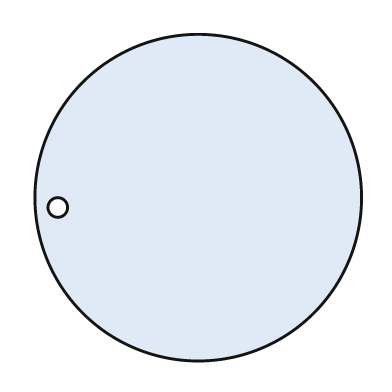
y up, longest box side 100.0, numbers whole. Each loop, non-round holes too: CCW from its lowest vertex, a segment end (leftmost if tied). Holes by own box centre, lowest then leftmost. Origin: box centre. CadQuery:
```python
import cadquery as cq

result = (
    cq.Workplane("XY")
    .moveTo(0.0, 0.0)
    .circle(50.0)
    .moveTo(-43.0, -3.0)
    .circle(3.0)
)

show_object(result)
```